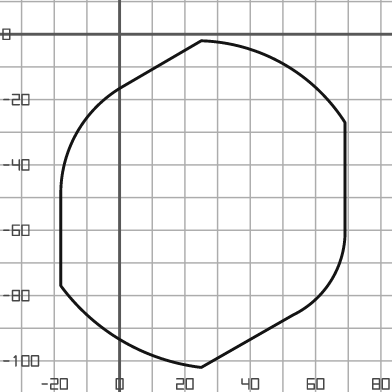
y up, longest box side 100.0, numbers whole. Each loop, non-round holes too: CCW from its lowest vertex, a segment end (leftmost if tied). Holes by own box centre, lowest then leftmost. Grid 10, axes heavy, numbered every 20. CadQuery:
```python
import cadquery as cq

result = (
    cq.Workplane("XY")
    .moveTo(25.0, -102.0)
    .lineTo(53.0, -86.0)
    .threePointArc((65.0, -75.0), (69.0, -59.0))
    .lineTo(69.0, -27.0)
    .threePointArc((50.0, -9.0), (25.0, -2.0))
    .lineTo(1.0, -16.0)
    .threePointArc((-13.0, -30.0), (-18.0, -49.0))
    .lineTo(-18.0, -77.0)
    .threePointArc((1.0, -94.0), (25.0, -102.0))
    .close()
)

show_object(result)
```